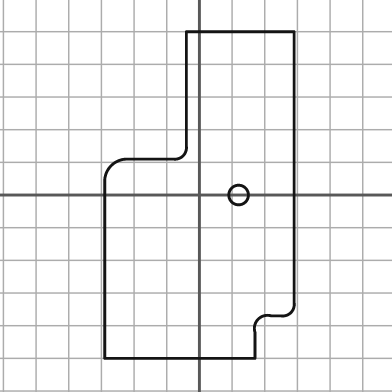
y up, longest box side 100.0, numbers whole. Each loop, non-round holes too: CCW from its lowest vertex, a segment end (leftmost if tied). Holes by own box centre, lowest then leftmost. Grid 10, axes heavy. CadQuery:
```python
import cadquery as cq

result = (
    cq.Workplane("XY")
    .moveTo(-29.0, -50.0)
    .lineTo(17.0, -50.0)
    .lineTo(17.0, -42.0)
    .threePointArc((18.0, -38.0), (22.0, -37.0))
    .lineTo(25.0, -37.0)
    .threePointArc((28.0, -36.0), (29.0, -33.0))
    .lineTo(29.0, 50.0)
    .lineTo(-4.0, 50.0)
    .lineTo(-4.0, 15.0)
    .threePointArc((-5.0, 12.0), (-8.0, 11.0))
    .lineTo(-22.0, 11.0)
    .threePointArc((-27.0, 9.0), (-29.0, 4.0))
    .close()
    .moveTo(12.0, 0.0)
    .circle(3.0)
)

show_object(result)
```